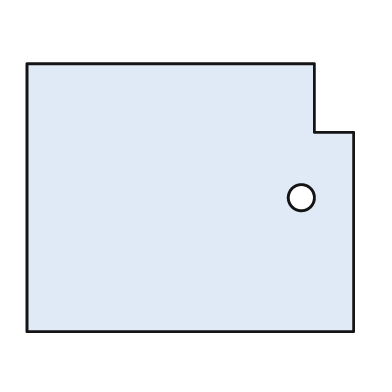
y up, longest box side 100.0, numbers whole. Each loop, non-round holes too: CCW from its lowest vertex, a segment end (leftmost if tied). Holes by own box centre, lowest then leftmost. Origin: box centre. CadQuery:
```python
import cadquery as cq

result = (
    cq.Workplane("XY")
    .moveTo(-50.0, -41.0)
    .lineTo(50.0, -41.0)
    .lineTo(50.0, 20.0)
    .lineTo(38.0, 20.0)
    .lineTo(38.0, 41.0)
    .lineTo(-50.0, 41.0)
    .close()
    .moveTo(34.0, 0.0)
    .circle(4.0)
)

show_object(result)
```